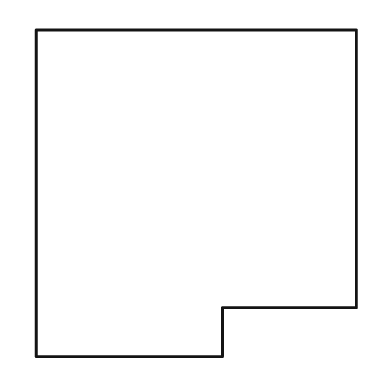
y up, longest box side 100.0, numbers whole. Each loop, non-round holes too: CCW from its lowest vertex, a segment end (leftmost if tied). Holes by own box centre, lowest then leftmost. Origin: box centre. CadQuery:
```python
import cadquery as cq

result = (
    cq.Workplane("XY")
    .moveTo(-49.0, -50.0)
    .lineTo(8.0, -50.0)
    .lineTo(8.0, -35.0)
    .lineTo(49.0, -35.0)
    .lineTo(49.0, 50.0)
    .lineTo(-49.0, 50.0)
    .close()
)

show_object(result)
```